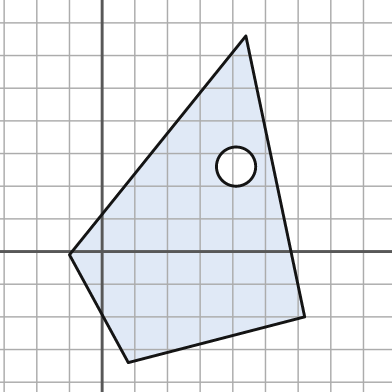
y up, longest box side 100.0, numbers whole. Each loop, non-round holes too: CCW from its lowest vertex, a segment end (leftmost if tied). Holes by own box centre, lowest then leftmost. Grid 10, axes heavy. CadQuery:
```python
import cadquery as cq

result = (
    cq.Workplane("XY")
    .moveTo(8.0, -34.0)
    .lineTo(62.0, -20.0)
    .lineTo(44.0, 66.0)
    .lineTo(-10.0, -1.0)
    .close()
    .moveTo(41.0, 26.0)
    .circle(6.0)
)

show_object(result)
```